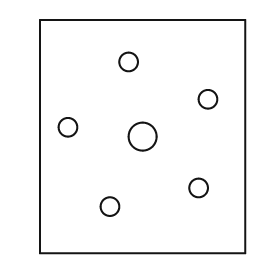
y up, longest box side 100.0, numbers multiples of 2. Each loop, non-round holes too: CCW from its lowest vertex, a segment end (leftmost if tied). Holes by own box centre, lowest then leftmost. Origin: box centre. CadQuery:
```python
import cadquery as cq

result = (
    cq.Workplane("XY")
    .moveTo(-44.0, -50.0)
    .lineTo(44.0, -50.0)
    .lineTo(44.0, 50.0)
    .lineTo(-44.0, 50.0)
    .close()
    .moveTo(-14.0, -30.0)
    .circle(4.0)
    .moveTo(24.0, -22.0)
    .circle(4.0)
    .moveTo(0.0, 0.0)
    .circle(6.0)
    .moveTo(-32.0, 4.0)
    .circle(4.0)
    .moveTo(28.0, 16.0)
    .circle(4.0)
    .moveTo(-6.0, 32.0)
    .circle(4.0)
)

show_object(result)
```